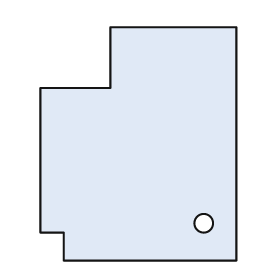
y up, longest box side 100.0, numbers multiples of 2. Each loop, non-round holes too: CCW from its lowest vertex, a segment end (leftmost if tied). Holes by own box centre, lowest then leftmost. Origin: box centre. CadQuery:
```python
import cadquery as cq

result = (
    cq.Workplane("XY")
    .moveTo(-32.0, -50.0)
    .lineTo(42.0, -50.0)
    .lineTo(42.0, 50.0)
    .lineTo(-12.0, 50.0)
    .lineTo(-12.0, 24.0)
    .lineTo(-42.0, 24.0)
    .lineTo(-42.0, -38.0)
    .lineTo(-32.0, -38.0)
    .close()
    .moveTo(28.0, -34.0)
    .circle(4.0)
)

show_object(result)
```